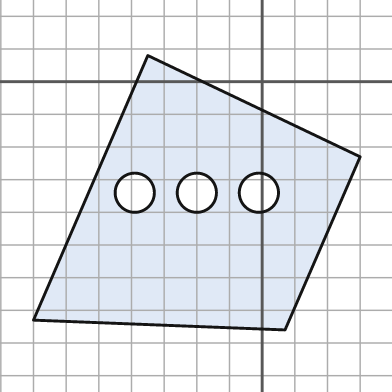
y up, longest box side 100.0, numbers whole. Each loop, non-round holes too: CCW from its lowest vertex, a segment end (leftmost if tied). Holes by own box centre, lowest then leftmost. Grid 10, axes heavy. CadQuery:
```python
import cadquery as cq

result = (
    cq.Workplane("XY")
    .moveTo(7.0, -76.0)
    .lineTo(30.0, -23.0)
    .lineTo(-35.0, 8.0)
    .lineTo(-70.0, -73.0)
    .close()
    .moveTo(-39.0, -34.0)
    .circle(6.0)
    .moveTo(-20.0, -34.0)
    .circle(6.0)
    .moveTo(-1.0, -34.0)
    .circle(6.0)
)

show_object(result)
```